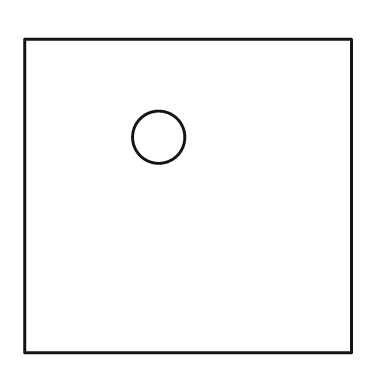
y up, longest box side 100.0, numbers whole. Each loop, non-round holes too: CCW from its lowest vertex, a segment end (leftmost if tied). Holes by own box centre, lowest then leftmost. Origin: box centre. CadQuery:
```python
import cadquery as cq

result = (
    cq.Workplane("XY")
    .moveTo(-50.0, -48.0)
    .lineTo(50.0, -48.0)
    .lineTo(50.0, 48.0)
    .lineTo(-50.0, 48.0)
    .close()
    .moveTo(-9.0, 18.0)
    .circle(8.0)
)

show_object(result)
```